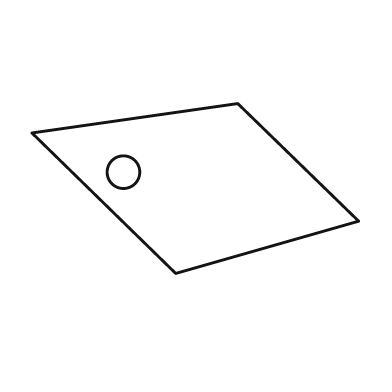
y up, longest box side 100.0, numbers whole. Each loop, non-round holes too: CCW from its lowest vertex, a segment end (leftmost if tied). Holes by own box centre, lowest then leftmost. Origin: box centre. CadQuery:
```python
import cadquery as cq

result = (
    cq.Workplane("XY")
    .moveTo(-6.0, -26.0)
    .lineTo(50.0, -10.0)
    .lineTo(13.0, 26.0)
    .lineTo(-50.0, 17.0)
    .close()
    .moveTo(-22.0, 5.0)
    .circle(5.0)
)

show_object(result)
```